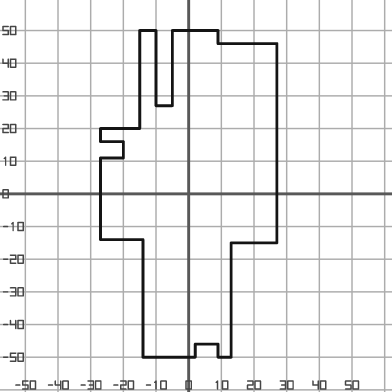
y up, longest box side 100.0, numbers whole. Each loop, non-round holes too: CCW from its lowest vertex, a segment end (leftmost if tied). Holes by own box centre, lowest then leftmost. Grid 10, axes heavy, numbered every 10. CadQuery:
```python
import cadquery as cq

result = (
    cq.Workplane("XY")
    .moveTo(-14.0, -50.0)
    .lineTo(2.0, -50.0)
    .lineTo(2.0, -46.0)
    .lineTo(9.0, -46.0)
    .lineTo(9.0, -50.0)
    .lineTo(13.0, -50.0)
    .lineTo(13.0, -15.0)
    .lineTo(27.0, -15.0)
    .lineTo(27.0, 46.0)
    .lineTo(9.0, 46.0)
    .lineTo(9.0, 50.0)
    .lineTo(-5.0, 50.0)
    .lineTo(-5.0, 27.0)
    .lineTo(-10.0, 27.0)
    .lineTo(-10.0, 50.0)
    .lineTo(-15.0, 50.0)
    .lineTo(-15.0, 20.0)
    .lineTo(-27.0, 20.0)
    .lineTo(-27.0, 16.0)
    .lineTo(-20.0, 16.0)
    .lineTo(-20.0, 11.0)
    .lineTo(-27.0, 11.0)
    .lineTo(-27.0, -14.0)
    .lineTo(-14.0, -14.0)
    .close()
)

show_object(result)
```